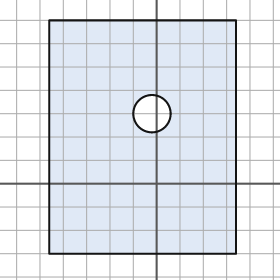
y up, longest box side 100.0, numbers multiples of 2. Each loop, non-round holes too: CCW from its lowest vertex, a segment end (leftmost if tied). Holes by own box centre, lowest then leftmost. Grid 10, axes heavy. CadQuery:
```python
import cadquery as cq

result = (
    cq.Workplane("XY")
    .moveTo(-46.0, -30.0)
    .lineTo(34.0, -30.0)
    .lineTo(34.0, 70.0)
    .lineTo(-46.0, 70.0)
    .close()
    .moveTo(-2.0, 30.0)
    .circle(8.0)
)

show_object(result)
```